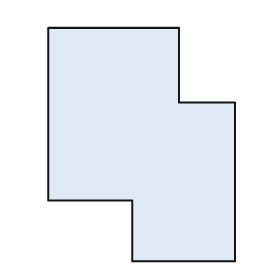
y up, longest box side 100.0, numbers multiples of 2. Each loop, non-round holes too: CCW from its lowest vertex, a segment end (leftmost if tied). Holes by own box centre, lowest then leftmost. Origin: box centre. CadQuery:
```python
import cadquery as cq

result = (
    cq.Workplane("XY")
    .moveTo(-4.0, -50.0)
    .lineTo(40.0, -50.0)
    .lineTo(40.0, 18.0)
    .lineTo(16.0, 18.0)
    .lineTo(16.0, 50.0)
    .lineTo(-40.0, 50.0)
    .lineTo(-40.0, -24.0)
    .lineTo(-4.0, -24.0)
    .close()
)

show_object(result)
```